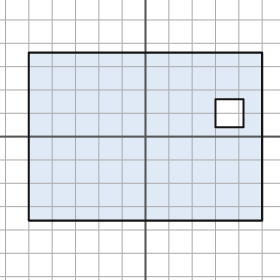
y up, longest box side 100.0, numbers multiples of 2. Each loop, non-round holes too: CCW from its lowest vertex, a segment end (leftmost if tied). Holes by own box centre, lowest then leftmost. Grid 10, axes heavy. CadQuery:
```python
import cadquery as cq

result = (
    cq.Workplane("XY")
    .moveTo(-50.0, -36.0)
    .lineTo(50.0, -36.0)
    .lineTo(50.0, 36.0)
    .lineTo(-50.0, 36.0)
    .close()
    .moveTo(30.0, 4.0)
    .lineTo(42.0, 4.0)
    .lineTo(42.0, 16.0)
    .lineTo(30.0, 16.0)
    .close()
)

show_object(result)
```